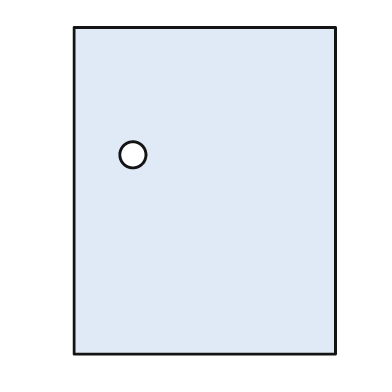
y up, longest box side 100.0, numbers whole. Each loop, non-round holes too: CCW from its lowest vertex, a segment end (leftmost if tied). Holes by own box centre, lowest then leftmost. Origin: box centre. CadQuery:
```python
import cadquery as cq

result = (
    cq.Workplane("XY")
    .moveTo(-40.0, -50.0)
    .lineTo(40.0, -50.0)
    .lineTo(40.0, 50.0)
    .lineTo(-40.0, 50.0)
    .close()
    .moveTo(-22.0, 11.0)
    .circle(4.0)
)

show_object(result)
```